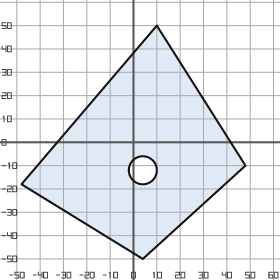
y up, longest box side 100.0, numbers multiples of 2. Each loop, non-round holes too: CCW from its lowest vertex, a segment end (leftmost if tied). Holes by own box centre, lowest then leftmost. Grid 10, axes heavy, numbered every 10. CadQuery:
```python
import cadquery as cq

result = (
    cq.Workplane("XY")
    .moveTo(4.0, -50.0)
    .lineTo(48.0, -10.0)
    .lineTo(10.0, 50.0)
    .lineTo(-48.0, -18.0)
    .close()
    .moveTo(4.0, -12.0)
    .circle(6.0)
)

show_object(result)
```